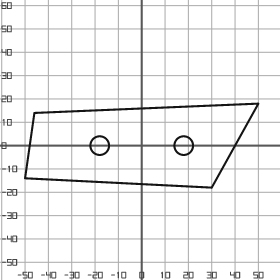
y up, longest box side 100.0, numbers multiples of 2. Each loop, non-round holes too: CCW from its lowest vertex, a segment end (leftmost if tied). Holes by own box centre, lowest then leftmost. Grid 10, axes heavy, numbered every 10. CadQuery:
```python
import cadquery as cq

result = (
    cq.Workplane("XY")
    .moveTo(30.0, -18.0)
    .lineTo(50.0, 18.0)
    .lineTo(-46.0, 14.0)
    .lineTo(-50.0, -14.0)
    .close()
    .moveTo(-18.0, 0.0)
    .circle(4.0)
    .moveTo(18.0, 0.0)
    .circle(4.0)
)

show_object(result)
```